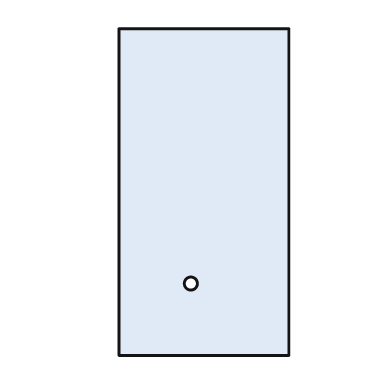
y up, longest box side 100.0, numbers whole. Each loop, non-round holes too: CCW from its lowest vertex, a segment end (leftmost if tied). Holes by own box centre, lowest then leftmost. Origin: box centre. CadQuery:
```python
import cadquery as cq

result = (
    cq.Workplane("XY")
    .moveTo(-26.0, -50.0)
    .lineTo(26.0, -50.0)
    .lineTo(26.0, 50.0)
    .lineTo(-26.0, 50.0)
    .close()
    .moveTo(-4.0, -28.0)
    .circle(2.0)
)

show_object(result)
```